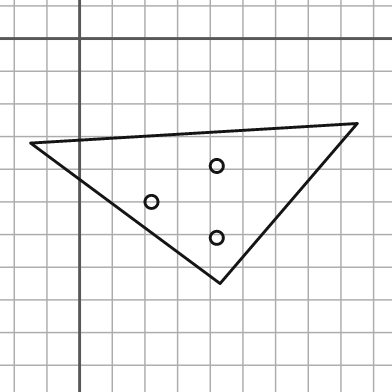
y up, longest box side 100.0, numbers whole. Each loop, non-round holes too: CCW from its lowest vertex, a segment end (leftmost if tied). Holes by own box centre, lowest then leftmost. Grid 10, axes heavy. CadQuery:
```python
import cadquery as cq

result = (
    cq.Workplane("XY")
    .moveTo(43.0, -75.0)
    .lineTo(85.0, -26.0)
    .lineTo(-15.0, -32.0)
    .close()
    .moveTo(42.0, -61.0)
    .circle(2.0)
    .moveTo(22.0, -50.0)
    .circle(2.0)
    .moveTo(42.0, -39.0)
    .circle(2.0)
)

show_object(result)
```